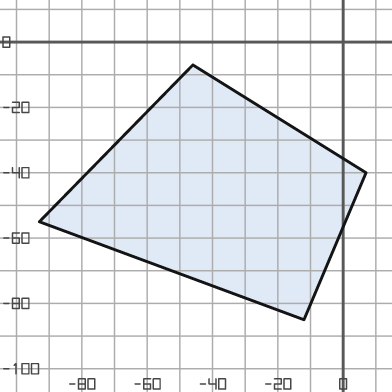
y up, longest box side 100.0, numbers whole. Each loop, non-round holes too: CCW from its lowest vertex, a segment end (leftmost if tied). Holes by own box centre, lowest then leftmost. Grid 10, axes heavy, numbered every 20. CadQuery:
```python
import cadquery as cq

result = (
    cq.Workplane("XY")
    .moveTo(-12.0, -85.0)
    .lineTo(7.0, -40.0)
    .lineTo(-46.0, -7.0)
    .lineTo(-93.0, -55.0)
    .close()
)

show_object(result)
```